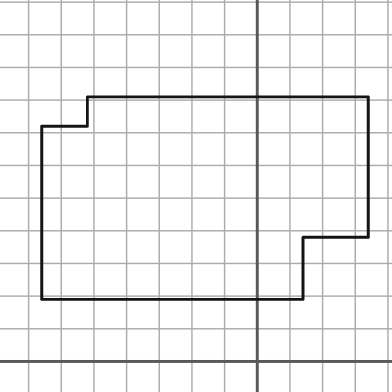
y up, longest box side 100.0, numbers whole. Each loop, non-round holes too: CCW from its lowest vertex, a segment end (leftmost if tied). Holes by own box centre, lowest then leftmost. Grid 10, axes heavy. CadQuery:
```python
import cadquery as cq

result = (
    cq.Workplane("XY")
    .moveTo(-66.0, 19.0)
    .lineTo(14.0, 19.0)
    .lineTo(14.0, 38.0)
    .lineTo(34.0, 38.0)
    .lineTo(34.0, 81.0)
    .lineTo(-52.0, 81.0)
    .lineTo(-52.0, 72.0)
    .lineTo(-66.0, 72.0)
    .close()
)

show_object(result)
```